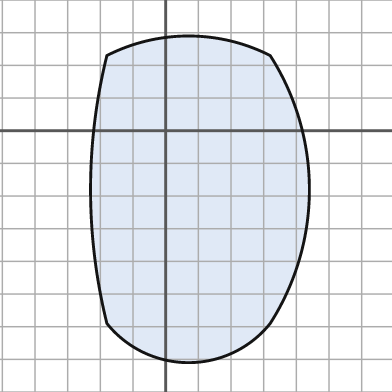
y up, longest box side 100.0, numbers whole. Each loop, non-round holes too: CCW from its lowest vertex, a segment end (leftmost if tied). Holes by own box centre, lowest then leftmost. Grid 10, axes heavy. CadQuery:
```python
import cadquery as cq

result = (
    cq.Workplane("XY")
    .moveTo(-18.0, -59.0)
    .threePointArc((7.0, -71.0), (32.0, -59.0))
    .threePointArc((44.0, -18.0), (32.0, 23.0))
    .threePointArc((7.0, 29.0), (-18.0, 23.0))
    .threePointArc((-23.0, -18.0), (-18.0, -59.0))
    .close()
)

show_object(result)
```